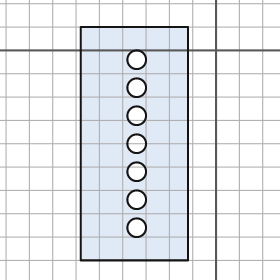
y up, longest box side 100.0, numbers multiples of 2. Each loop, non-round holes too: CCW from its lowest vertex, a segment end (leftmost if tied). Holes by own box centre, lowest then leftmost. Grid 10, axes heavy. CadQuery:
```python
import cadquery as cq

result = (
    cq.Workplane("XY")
    .moveTo(-58.0, -90.0)
    .lineTo(-12.0, -90.0)
    .lineTo(-12.0, 10.0)
    .lineTo(-58.0, 10.0)
    .close()
    .moveTo(-34.0, -76.0)
    .circle(4.0)
    .moveTo(-34.0, -64.0)
    .circle(4.0)
    .moveTo(-34.0, -52.0)
    .circle(4.0)
    .moveTo(-34.0, -40.0)
    .circle(4.0)
    .moveTo(-34.0, -28.0)
    .circle(4.0)
    .moveTo(-34.0, -16.0)
    .circle(4.0)
    .moveTo(-34.0, -4.0)
    .circle(4.0)
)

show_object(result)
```